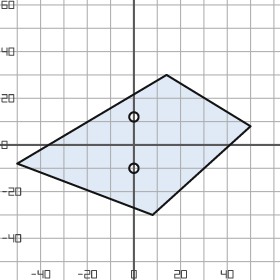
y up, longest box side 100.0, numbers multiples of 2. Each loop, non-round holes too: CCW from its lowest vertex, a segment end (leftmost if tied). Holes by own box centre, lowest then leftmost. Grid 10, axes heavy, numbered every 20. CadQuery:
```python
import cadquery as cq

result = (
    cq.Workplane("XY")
    .moveTo(8.0, -30.0)
    .lineTo(50.0, 8.0)
    .lineTo(14.0, 30.0)
    .lineTo(-50.0, -8.0)
    .close()
    .moveTo(0.0, -10.0)
    .circle(2.0)
    .moveTo(0.0, 12.0)
    .circle(2.0)
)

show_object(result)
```